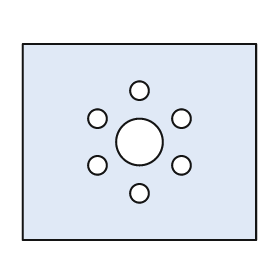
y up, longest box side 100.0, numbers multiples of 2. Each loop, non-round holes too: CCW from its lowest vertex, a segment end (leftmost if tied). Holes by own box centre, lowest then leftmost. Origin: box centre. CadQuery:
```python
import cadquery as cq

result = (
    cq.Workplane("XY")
    .moveTo(-50.0, -42.0)
    .lineTo(50.0, -42.0)
    .lineTo(50.0, 42.0)
    .lineTo(-50.0, 42.0)
    .close()
    .moveTo(0.0, -22.0)
    .circle(4.0)
    .moveTo(-18.0, -10.0)
    .circle(4.0)
    .moveTo(18.0, -10.0)
    .circle(4.0)
    .moveTo(0.0, 0.0)
    .circle(10.0)
    .moveTo(-18.0, 10.0)
    .circle(4.0)
    .moveTo(18.0, 10.0)
    .circle(4.0)
    .moveTo(0.0, 22.0)
    .circle(4.0)
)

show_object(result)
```